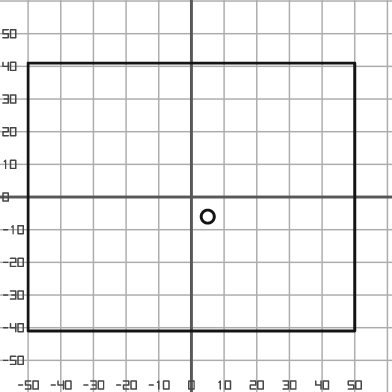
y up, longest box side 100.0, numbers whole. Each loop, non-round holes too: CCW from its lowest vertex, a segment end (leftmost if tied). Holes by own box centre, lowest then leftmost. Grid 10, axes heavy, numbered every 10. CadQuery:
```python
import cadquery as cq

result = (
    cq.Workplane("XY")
    .moveTo(-50.0, -41.0)
    .lineTo(50.0, -41.0)
    .lineTo(50.0, 41.0)
    .lineTo(-50.0, 41.0)
    .close()
    .moveTo(5.0, -6.0)
    .circle(2.0)
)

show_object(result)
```